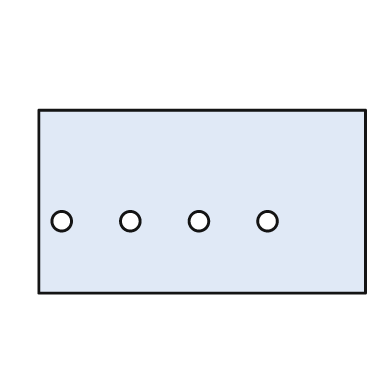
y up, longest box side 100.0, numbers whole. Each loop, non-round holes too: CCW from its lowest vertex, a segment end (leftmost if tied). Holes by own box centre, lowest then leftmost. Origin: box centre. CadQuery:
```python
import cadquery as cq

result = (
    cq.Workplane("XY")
    .moveTo(-50.0, -28.0)
    .lineTo(50.0, -28.0)
    .lineTo(50.0, 28.0)
    .lineTo(-50.0, 28.0)
    .close()
    .moveTo(-43.0, -6.0)
    .circle(3.0)
    .moveTo(-22.0, -6.0)
    .circle(3.0)
    .moveTo(-1.0, -6.0)
    .circle(3.0)
    .moveTo(20.0, -6.0)
    .circle(3.0)
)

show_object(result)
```